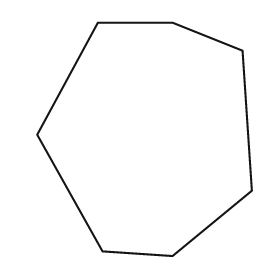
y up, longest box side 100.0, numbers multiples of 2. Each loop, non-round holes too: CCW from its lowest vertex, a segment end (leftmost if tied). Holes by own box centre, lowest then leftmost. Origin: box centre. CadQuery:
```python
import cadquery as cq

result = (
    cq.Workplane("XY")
    .moveTo(12.0, -50.0)
    .lineTo(46.0, -22.0)
    .lineTo(42.0, 38.0)
    .lineTo(12.0, 50.0)
    .lineTo(-20.0, 50.0)
    .lineTo(-46.0, 2.0)
    .lineTo(-18.0, -48.0)
    .close()
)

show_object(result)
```